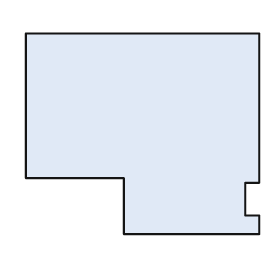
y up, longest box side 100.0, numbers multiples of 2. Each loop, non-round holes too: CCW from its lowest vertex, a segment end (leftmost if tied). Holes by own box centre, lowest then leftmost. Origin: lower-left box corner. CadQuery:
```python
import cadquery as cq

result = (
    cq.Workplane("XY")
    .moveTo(42.0, 0.0)
    .lineTo(100.0, 0.0)
    .lineTo(100.0, 8.0)
    .lineTo(94.0, 8.0)
    .lineTo(94.0, 22.0)
    .lineTo(100.0, 22.0)
    .lineTo(100.0, 86.0)
    .lineTo(0.0, 86.0)
    .lineTo(0.0, 24.0)
    .lineTo(42.0, 24.0)
    .close()
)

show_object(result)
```